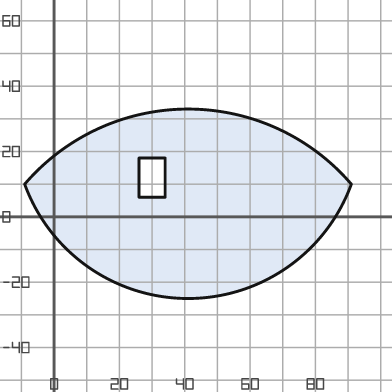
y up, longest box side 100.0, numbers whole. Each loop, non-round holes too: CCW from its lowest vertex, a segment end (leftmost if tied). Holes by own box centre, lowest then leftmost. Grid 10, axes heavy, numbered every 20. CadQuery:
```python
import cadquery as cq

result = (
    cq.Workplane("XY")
    .moveTo(-9.0, 10.0)
    .threePointArc((41.0, -25.0), (91.0, 10.0))
    .threePointArc((41.0, 33.0), (-9.0, 10.0))
    .close()
    .moveTo(26.0, 6.0)
    .lineTo(34.0, 6.0)
    .lineTo(34.0, 18.0)
    .lineTo(26.0, 18.0)
    .close()
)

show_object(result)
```